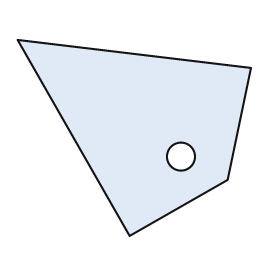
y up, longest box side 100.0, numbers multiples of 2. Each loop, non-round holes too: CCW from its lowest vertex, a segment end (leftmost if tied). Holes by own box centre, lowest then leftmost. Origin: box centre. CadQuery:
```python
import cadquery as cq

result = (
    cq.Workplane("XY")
    .moveTo(-2.0, -42.0)
    .lineTo(40.0, -18.0)
    .lineTo(50.0, 30.0)
    .lineTo(-50.0, 42.0)
    .close()
    .moveTo(20.0, -8.0)
    .circle(6.0)
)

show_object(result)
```